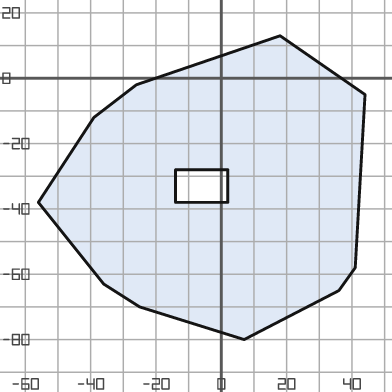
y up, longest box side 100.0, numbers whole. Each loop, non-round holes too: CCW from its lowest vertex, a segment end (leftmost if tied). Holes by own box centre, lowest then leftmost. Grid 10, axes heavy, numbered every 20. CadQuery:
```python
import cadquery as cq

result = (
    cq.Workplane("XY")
    .moveTo(7.0, -80.0)
    .lineTo(36.0, -65.0)
    .lineTo(41.0, -58.0)
    .lineTo(44.0, -5.0)
    .lineTo(18.0, 13.0)
    .lineTo(-26.0, -2.0)
    .lineTo(-39.0, -12.0)
    .lineTo(-56.0, -38.0)
    .lineTo(-36.0, -63.0)
    .lineTo(-25.0, -70.0)
    .close()
    .moveTo(-14.0, -38.0)
    .lineTo(2.0, -38.0)
    .lineTo(2.0, -28.0)
    .lineTo(-14.0, -28.0)
    .close()
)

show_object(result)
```